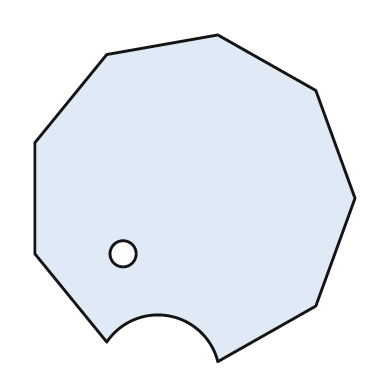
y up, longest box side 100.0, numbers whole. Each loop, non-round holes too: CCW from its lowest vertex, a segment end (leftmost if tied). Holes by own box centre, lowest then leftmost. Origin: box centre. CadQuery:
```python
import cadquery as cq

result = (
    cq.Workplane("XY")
    .moveTo(7.0, -50.0)
    .lineTo(37.0, -33.0)
    .lineTo(49.0, 0.0)
    .lineTo(37.0, 33.0)
    .lineTo(7.0, 50.0)
    .lineTo(-27.0, 44.0)
    .lineTo(-49.0, 17.0)
    .lineTo(-49.0, -17.0)
    .lineTo(-27.0, -44.0)
    .threePointArc((-8.0, -36.0), (7.0, -50.0))
    .close()
    .moveTo(-22.0, -17.0)
    .circle(4.0)
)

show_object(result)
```